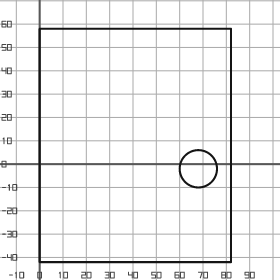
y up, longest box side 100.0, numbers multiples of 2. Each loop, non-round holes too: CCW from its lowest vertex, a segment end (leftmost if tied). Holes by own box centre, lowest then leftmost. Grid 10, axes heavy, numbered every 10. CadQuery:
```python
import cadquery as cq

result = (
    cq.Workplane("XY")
    .moveTo(0.0, -42.0)
    .lineTo(82.0, -42.0)
    .lineTo(82.0, 58.0)
    .lineTo(0.0, 58.0)
    .close()
    .moveTo(68.0, -2.0)
    .circle(8.0)
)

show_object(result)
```